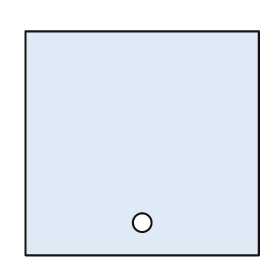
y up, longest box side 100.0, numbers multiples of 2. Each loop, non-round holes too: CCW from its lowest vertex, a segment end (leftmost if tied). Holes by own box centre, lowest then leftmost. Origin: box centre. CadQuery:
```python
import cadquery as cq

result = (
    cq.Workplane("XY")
    .moveTo(-50.0, -48.0)
    .lineTo(50.0, -48.0)
    .lineTo(50.0, 48.0)
    .lineTo(-50.0, 48.0)
    .close()
    .moveTo(0.0, -34.0)
    .circle(4.0)
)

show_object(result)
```